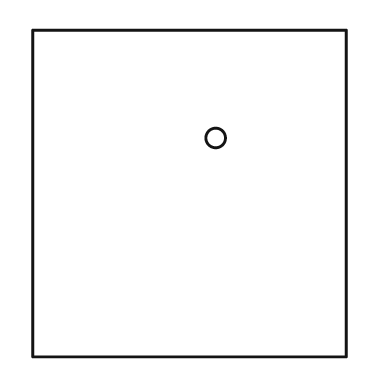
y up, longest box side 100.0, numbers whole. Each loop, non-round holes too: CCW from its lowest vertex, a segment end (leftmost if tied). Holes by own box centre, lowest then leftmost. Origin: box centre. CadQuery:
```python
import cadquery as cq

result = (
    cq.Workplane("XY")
    .moveTo(-48.0, -50.0)
    .lineTo(48.0, -50.0)
    .lineTo(48.0, 50.0)
    .lineTo(-48.0, 50.0)
    .close()
    .moveTo(8.0, 17.0)
    .circle(3.0)
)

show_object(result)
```